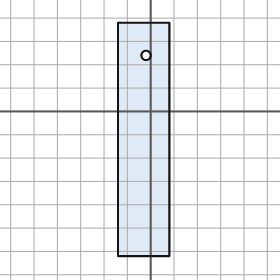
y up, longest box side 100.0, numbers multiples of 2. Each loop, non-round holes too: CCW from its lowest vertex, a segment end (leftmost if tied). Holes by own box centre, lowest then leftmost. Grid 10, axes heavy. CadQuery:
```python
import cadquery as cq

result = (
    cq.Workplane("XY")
    .moveTo(-14.0, -62.0)
    .lineTo(8.0, -62.0)
    .lineTo(8.0, 38.0)
    .lineTo(-14.0, 38.0)
    .close()
    .moveTo(-2.0, 24.0)
    .circle(2.0)
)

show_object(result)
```